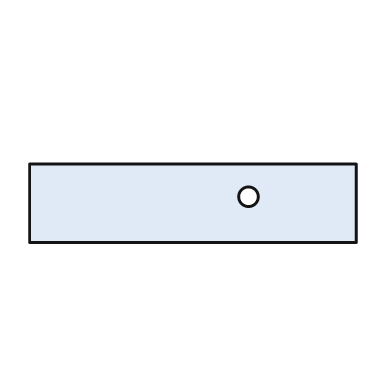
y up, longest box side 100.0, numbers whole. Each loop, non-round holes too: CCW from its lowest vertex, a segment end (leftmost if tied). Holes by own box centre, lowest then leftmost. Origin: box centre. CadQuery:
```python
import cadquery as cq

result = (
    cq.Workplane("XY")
    .moveTo(-50.0, -12.0)
    .lineTo(50.0, -12.0)
    .lineTo(50.0, 12.0)
    .lineTo(-50.0, 12.0)
    .close()
    .moveTo(17.0, 2.0)
    .circle(3.0)
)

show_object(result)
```